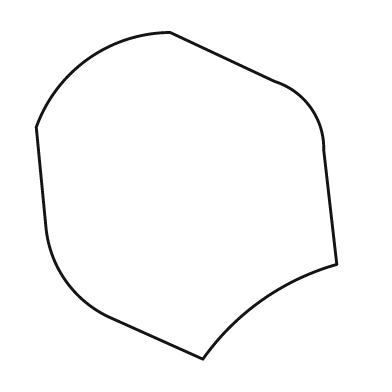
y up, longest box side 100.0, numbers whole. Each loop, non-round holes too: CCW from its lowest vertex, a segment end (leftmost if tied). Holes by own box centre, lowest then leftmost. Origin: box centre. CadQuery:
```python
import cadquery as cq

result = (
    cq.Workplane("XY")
    .moveTo(5.0, -50.0)
    .threePointArc((23.0, -32.0), (46.0, -21.0))
    .lineTo(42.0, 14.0)
    .threePointArc((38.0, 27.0), (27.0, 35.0))
    .lineTo(-5.0, 50.0)
    .threePointArc((-30.0, 42.0), (-46.0, 21.0))
    .lineTo(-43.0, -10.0)
    .threePointArc((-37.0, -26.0), (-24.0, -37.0))
    .close()
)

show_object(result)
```